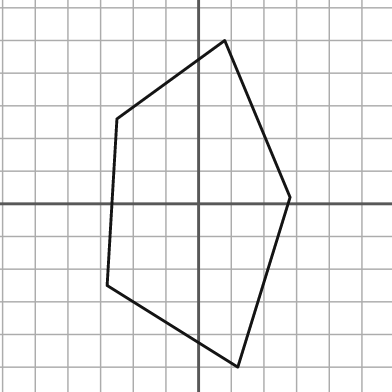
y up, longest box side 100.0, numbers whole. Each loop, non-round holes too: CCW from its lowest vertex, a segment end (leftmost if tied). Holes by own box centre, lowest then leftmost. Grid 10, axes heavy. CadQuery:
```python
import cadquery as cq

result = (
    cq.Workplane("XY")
    .moveTo(12.0, -50.0)
    .lineTo(28.0, 2.0)
    .lineTo(8.0, 50.0)
    .lineTo(-25.0, 26.0)
    .lineTo(-28.0, -25.0)
    .close()
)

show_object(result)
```